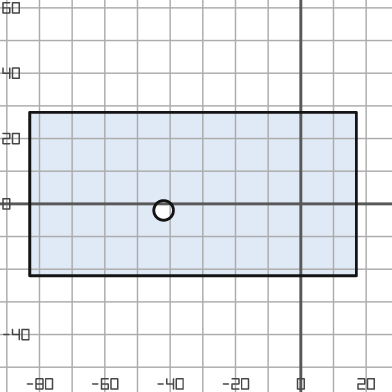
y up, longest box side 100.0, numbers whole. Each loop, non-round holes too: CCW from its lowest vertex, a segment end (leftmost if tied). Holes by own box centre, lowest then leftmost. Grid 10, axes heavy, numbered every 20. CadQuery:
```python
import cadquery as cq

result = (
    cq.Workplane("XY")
    .moveTo(-83.0, -22.0)
    .lineTo(17.0, -22.0)
    .lineTo(17.0, 28.0)
    .lineTo(-83.0, 28.0)
    .close()
    .moveTo(-42.0, -2.0)
    .circle(3.0)
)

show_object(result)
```